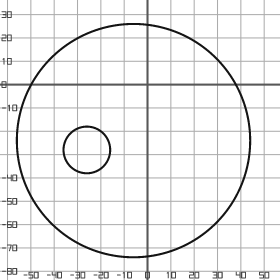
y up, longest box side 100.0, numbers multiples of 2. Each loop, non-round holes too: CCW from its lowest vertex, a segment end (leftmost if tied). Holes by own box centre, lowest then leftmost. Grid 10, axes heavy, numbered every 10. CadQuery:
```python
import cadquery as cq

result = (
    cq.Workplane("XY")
    .moveTo(-6.0, -24.0)
    .circle(50.0)
    .moveTo(-26.0, -28.0)
    .circle(10.0)
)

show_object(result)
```